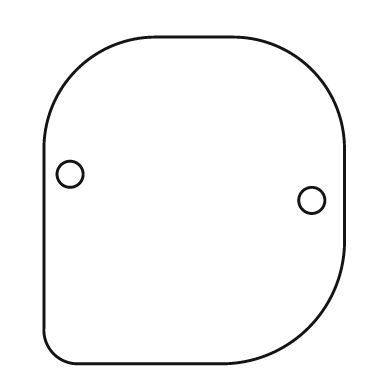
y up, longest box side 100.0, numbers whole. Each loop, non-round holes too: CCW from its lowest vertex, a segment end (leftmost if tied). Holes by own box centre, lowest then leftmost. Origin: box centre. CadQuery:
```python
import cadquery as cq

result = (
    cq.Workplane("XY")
    .moveTo(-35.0, -50.0)
    .lineTo(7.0, -50.0)
    .threePointArc((35.0, -39.0), (46.0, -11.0))
    .lineTo(46.0, 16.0)
    .threePointArc((36.0, 40.0), (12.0, 50.0))
    .lineTo(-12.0, 50.0)
    .threePointArc((-36.0, 40.0), (-46.0, 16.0))
    .lineTo(-46.0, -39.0)
    .threePointArc((-43.0, -47.0), (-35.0, -50.0))
    .close()
    .moveTo(36.0, 0.0)
    .circle(4.0)
    .moveTo(-38.0, 8.0)
    .circle(4.0)
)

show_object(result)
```